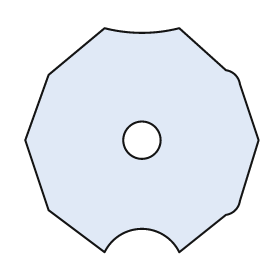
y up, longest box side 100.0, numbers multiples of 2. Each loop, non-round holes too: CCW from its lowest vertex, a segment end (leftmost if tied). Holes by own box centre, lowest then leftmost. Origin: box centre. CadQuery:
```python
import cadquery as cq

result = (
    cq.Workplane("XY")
    .moveTo(-16.0, -48.0)
    .threePointArc((0.0, -38.0), (16.0, -48.0))
    .lineTo(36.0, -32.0)
    .threePointArc((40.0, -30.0), (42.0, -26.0))
    .lineTo(50.0, 0.0)
    .lineTo(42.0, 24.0)
    .threePointArc((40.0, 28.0), (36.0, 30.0))
    .lineTo(16.0, 48.0)
    .threePointArc((0.0, 46.0), (-16.0, 48.0))
    .lineTo(-40.0, 28.0)
    .lineTo(-50.0, 0.0)
    .lineTo(-40.0, -30.0)
    .close()
    .moveTo(0.0, 0.0)
    .circle(8.0)
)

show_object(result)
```